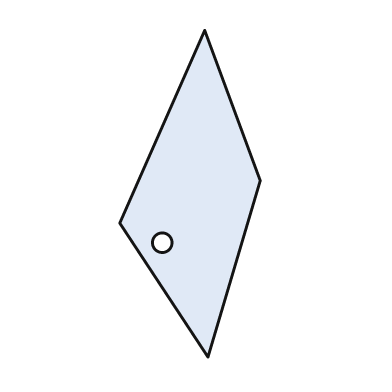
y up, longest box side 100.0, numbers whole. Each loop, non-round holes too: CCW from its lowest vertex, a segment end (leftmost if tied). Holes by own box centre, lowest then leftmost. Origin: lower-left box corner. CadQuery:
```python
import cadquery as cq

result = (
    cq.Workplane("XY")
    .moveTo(27.0, 0.0)
    .lineTo(43.0, 54.0)
    .lineTo(26.0, 100.0)
    .lineTo(0.0, 41.0)
    .close()
    .moveTo(13.0, 35.0)
    .circle(3.0)
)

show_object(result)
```